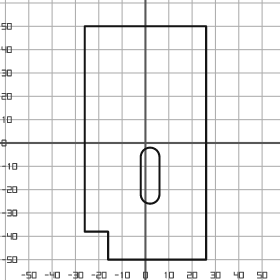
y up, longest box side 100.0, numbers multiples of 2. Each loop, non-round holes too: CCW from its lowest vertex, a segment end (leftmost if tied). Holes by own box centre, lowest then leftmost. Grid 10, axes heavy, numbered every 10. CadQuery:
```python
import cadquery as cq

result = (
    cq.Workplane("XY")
    .moveTo(-16.0, -50.0)
    .lineTo(26.0, -50.0)
    .lineTo(26.0, 50.0)
    .lineTo(-26.0, 50.0)
    .lineTo(-26.0, -38.0)
    .lineTo(-16.0, -38.0)
    .close()
    .moveTo(-2.0, -22.0)
    .threePointArc((2.0, -26.0), (6.0, -22.0))
    .lineTo(6.0, -6.0)
    .threePointArc((2.0, -2.0), (-2.0, -6.0))
    .close()
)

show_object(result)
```